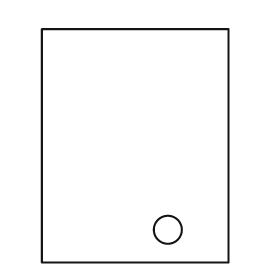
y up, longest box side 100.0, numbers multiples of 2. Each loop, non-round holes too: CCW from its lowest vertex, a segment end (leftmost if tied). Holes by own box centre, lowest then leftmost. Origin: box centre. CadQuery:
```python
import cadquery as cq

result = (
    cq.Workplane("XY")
    .moveTo(-40.0, -50.0)
    .lineTo(40.0, -50.0)
    .lineTo(40.0, 50.0)
    .lineTo(-40.0, 50.0)
    .close()
    .moveTo(14.0, -36.0)
    .circle(6.0)
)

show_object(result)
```